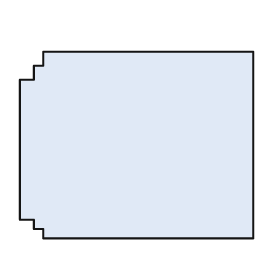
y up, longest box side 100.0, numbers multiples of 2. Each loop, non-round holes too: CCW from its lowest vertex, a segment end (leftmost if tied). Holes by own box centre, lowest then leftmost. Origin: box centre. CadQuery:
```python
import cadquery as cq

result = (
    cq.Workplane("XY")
    .moveTo(-40.0, -40.0)
    .lineTo(50.0, -40.0)
    .lineTo(50.0, 40.0)
    .lineTo(-40.0, 40.0)
    .lineTo(-40.0, 34.0)
    .lineTo(-44.0, 34.0)
    .lineTo(-44.0, 28.0)
    .lineTo(-50.0, 28.0)
    .lineTo(-50.0, -32.0)
    .lineTo(-44.0, -32.0)
    .lineTo(-44.0, -36.0)
    .lineTo(-40.0, -36.0)
    .close()
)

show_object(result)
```